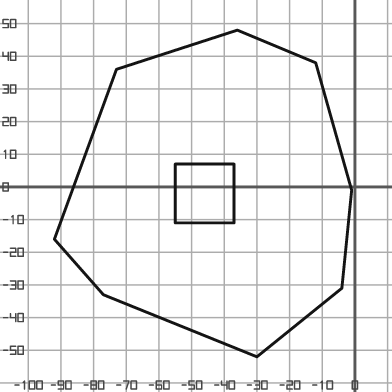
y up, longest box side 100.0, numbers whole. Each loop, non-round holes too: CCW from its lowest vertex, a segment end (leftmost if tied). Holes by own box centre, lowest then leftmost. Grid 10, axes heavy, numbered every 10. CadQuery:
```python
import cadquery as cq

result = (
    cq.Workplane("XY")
    .moveTo(-30.0, -52.0)
    .lineTo(-4.0, -31.0)
    .lineTo(-1.0, -1.0)
    .lineTo(-12.0, 38.0)
    .lineTo(-36.0, 48.0)
    .lineTo(-73.0, 36.0)
    .lineTo(-92.0, -16.0)
    .lineTo(-77.0, -33.0)
    .close()
    .moveTo(-55.0, -11.0)
    .lineTo(-37.0, -11.0)
    .lineTo(-37.0, 7.0)
    .lineTo(-55.0, 7.0)
    .close()
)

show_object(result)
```